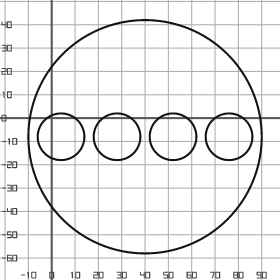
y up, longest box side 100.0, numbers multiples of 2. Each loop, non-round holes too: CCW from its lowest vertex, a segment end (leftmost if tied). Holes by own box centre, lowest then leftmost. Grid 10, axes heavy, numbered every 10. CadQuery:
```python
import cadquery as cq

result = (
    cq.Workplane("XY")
    .moveTo(40.0, -8.0)
    .circle(50.0)
    .moveTo(4.0, -8.0)
    .circle(10.0)
    .moveTo(28.0, -8.0)
    .circle(10.0)
    .moveTo(52.0, -8.0)
    .circle(10.0)
    .moveTo(76.0, -8.0)
    .circle(10.0)
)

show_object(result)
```